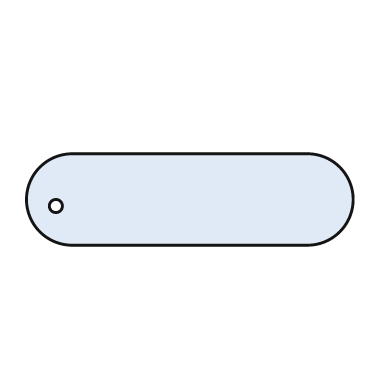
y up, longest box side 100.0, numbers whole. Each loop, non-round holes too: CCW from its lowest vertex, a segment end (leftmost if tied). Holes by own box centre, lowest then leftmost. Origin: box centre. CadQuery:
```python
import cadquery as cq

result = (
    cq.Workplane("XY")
    .moveTo(-36.0, -14.0)
    .lineTo(36.0, -14.0)
    .threePointArc((50.0, 0.0), (36.0, 14.0))
    .lineTo(-36.0, 14.0)
    .threePointArc((-50.0, 0.0), (-36.0, -14.0))
    .close()
    .moveTo(-41.0, -2.0)
    .circle(2.0)
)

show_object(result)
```